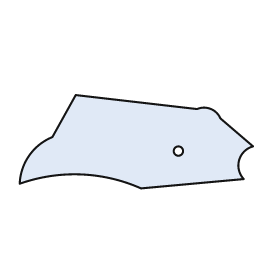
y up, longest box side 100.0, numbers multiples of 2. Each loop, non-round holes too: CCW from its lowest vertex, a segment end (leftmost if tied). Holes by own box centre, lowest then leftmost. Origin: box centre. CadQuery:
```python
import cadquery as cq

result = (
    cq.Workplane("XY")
    .moveTo(2.0, -20.0)
    .lineTo(46.0, -16.0)
    .threePointArc((44.0, -8.0), (50.0, -2.0))
    .lineTo(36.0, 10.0)
    .threePointArc((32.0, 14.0), (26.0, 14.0))
    .lineTo(-26.0, 20.0)
    .lineTo(-36.0, 2.0)
    .threePointArc((-46.0, -6.0), (-50.0, -18.0))
    .threePointArc((-24.0, -14.0), (2.0, -20.0))
    .close()
    .moveTo(18.0, -4.0)
    .circle(2.0)
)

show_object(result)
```